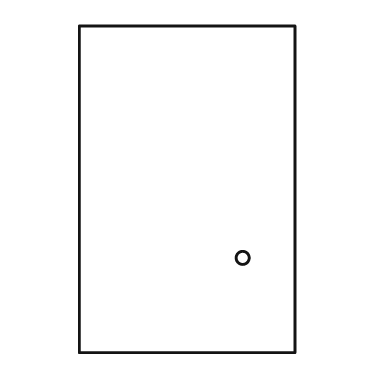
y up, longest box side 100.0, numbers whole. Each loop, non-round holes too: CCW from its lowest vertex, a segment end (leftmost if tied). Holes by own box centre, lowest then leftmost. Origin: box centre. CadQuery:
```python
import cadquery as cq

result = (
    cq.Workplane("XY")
    .moveTo(-33.0, -50.0)
    .lineTo(33.0, -50.0)
    .lineTo(33.0, 50.0)
    .lineTo(-33.0, 50.0)
    .close()
    .moveTo(17.0, -21.0)
    .circle(2.0)
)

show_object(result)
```